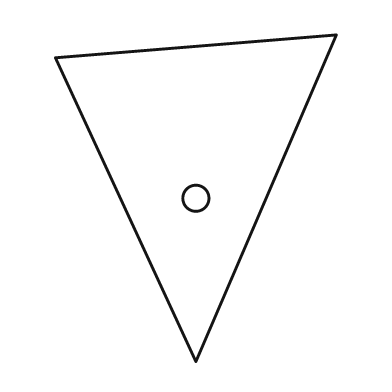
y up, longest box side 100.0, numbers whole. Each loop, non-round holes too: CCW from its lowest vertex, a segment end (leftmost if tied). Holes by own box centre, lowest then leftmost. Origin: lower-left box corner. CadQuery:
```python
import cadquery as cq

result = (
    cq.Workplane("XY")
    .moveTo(43.0, 0.0)
    .lineTo(86.0, 100.0)
    .lineTo(0.0, 93.0)
    .close()
    .moveTo(43.0, 50.0)
    .circle(4.0)
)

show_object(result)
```